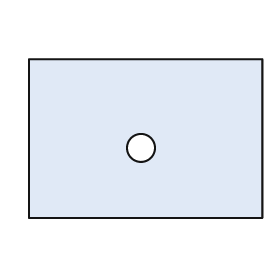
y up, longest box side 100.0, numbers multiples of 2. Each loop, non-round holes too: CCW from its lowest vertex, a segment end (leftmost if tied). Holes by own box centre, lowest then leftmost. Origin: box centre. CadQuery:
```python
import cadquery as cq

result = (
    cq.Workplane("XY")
    .moveTo(-50.0, -34.0)
    .lineTo(50.0, -34.0)
    .lineTo(50.0, 34.0)
    .lineTo(-50.0, 34.0)
    .close()
    .moveTo(-2.0, -4.0)
    .circle(6.0)
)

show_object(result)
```